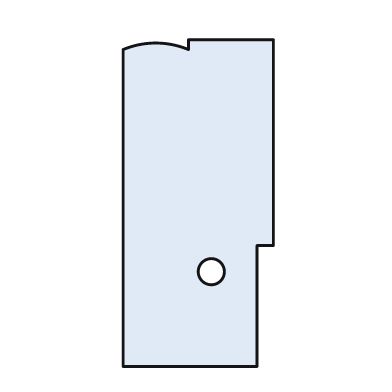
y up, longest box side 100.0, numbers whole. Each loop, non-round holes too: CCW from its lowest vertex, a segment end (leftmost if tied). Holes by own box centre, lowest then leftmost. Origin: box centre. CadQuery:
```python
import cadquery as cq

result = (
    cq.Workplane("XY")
    .moveTo(-23.0, -50.0)
    .lineTo(18.0, -50.0)
    .lineTo(18.0, -13.0)
    .lineTo(23.0, -13.0)
    .lineTo(23.0, 50.0)
    .lineTo(-3.0, 50.0)
    .lineTo(-3.0, 47.0)
    .threePointArc((-13.0, 49.0), (-23.0, 47.0))
    .close()
    .moveTo(4.0, -21.0)
    .circle(4.0)
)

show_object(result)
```